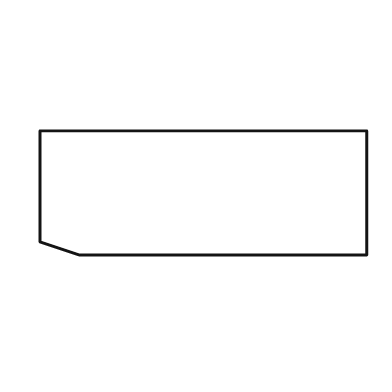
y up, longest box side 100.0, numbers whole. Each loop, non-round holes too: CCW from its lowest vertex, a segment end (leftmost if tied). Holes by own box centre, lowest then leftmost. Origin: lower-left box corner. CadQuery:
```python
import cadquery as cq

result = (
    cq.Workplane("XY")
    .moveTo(12.0, 0.0)
    .lineTo(100.0, 0.0)
    .lineTo(100.0, 38.0)
    .lineTo(0.0, 38.0)
    .lineTo(0.0, 4.0)
    .close()
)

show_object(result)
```